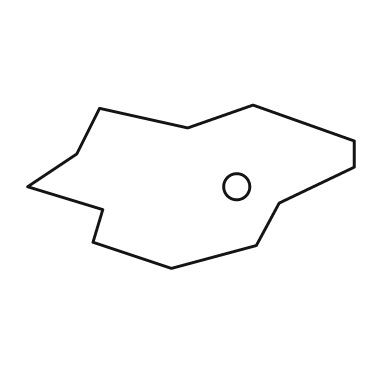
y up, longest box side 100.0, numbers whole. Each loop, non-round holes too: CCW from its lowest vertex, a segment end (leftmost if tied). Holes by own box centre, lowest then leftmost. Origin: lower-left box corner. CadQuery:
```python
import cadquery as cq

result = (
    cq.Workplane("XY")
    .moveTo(44.0, 0.0)
    .lineTo(70.0, 7.0)
    .lineTo(77.0, 20.0)
    .lineTo(100.0, 31.0)
    .lineTo(100.0, 39.0)
    .lineTo(69.0, 50.0)
    .lineTo(49.0, 43.0)
    .lineTo(22.0, 49.0)
    .lineTo(15.0, 35.0)
    .lineTo(0.0, 25.0)
    .lineTo(23.0, 18.0)
    .lineTo(20.0, 8.0)
    .close()
    .moveTo(64.0, 25.0)
    .circle(4.0)
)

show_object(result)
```